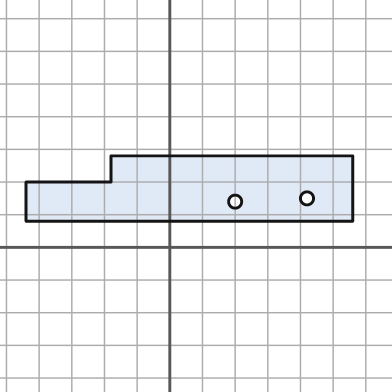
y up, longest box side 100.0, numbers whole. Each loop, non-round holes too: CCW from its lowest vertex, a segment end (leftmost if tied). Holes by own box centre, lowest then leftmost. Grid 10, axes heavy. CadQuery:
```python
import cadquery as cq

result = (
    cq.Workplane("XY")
    .moveTo(-44.0, 8.0)
    .lineTo(56.0, 8.0)
    .lineTo(56.0, 28.0)
    .lineTo(-18.0, 28.0)
    .lineTo(-18.0, 20.0)
    .lineTo(-44.0, 20.0)
    .close()
    .moveTo(20.0, 14.0)
    .circle(2.0)
    .moveTo(42.0, 15.0)
    .circle(2.0)
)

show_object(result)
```